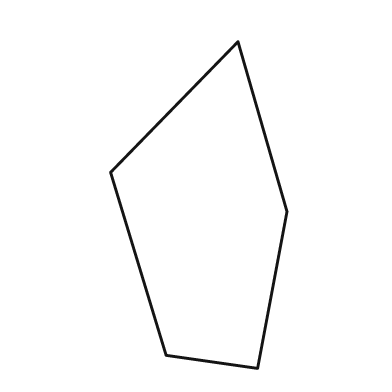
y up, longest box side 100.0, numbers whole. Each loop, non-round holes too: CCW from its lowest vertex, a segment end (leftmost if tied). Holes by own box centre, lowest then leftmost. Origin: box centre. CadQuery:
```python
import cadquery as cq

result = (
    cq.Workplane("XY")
    .moveTo(18.0, -50.0)
    .lineTo(27.0, -2.0)
    .lineTo(12.0, 50.0)
    .lineTo(-27.0, 10.0)
    .lineTo(-10.0, -46.0)
    .close()
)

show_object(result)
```